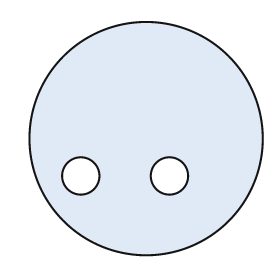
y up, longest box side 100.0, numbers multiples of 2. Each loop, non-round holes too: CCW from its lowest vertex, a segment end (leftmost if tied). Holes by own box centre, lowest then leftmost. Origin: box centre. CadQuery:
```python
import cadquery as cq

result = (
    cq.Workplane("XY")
    .moveTo(0.0, 0.0)
    .circle(50.0)
    .moveTo(-28.0, -16.0)
    .circle(8.0)
    .moveTo(10.0, -16.0)
    .circle(8.0)
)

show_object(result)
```